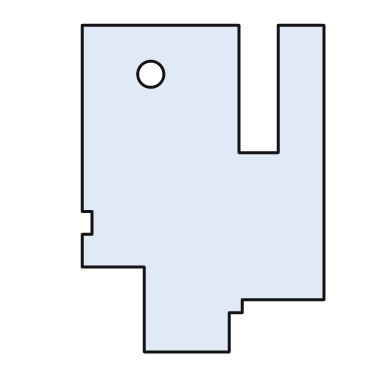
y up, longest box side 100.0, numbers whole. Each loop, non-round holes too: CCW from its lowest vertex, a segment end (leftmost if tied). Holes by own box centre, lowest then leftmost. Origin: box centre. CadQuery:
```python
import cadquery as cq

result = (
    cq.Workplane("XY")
    .moveTo(-18.0, -50.0)
    .lineTo(8.0, -50.0)
    .lineTo(8.0, -38.0)
    .lineTo(12.0, -38.0)
    .lineTo(12.0, -34.0)
    .lineTo(37.0, -34.0)
    .lineTo(37.0, 50.0)
    .lineTo(23.0, 50.0)
    .lineTo(23.0, 11.0)
    .lineTo(11.0, 11.0)
    .lineTo(11.0, 50.0)
    .lineTo(-37.0, 50.0)
    .lineTo(-37.0, -7.0)
    .lineTo(-34.0, -7.0)
    .lineTo(-34.0, -14.0)
    .lineTo(-37.0, -14.0)
    .lineTo(-37.0, -24.0)
    .lineTo(-18.0, -24.0)
    .close()
    .moveTo(-16.0, 35.0)
    .circle(4.0)
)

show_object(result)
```